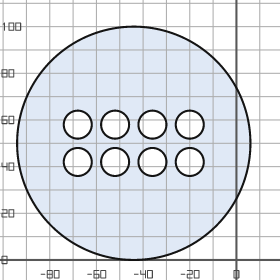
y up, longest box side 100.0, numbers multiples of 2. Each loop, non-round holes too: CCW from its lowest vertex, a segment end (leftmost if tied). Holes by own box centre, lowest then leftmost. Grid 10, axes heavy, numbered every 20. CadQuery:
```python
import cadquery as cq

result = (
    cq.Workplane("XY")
    .moveTo(-44.0, 50.0)
    .circle(50.0)
    .moveTo(-68.0, 42.0)
    .circle(6.0)
    .moveTo(-52.0, 42.0)
    .circle(6.0)
    .moveTo(-36.0, 42.0)
    .circle(6.0)
    .moveTo(-20.0, 42.0)
    .circle(6.0)
    .moveTo(-68.0, 58.0)
    .circle(6.0)
    .moveTo(-52.0, 58.0)
    .circle(6.0)
    .moveTo(-36.0, 58.0)
    .circle(6.0)
    .moveTo(-20.0, 58.0)
    .circle(6.0)
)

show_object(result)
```